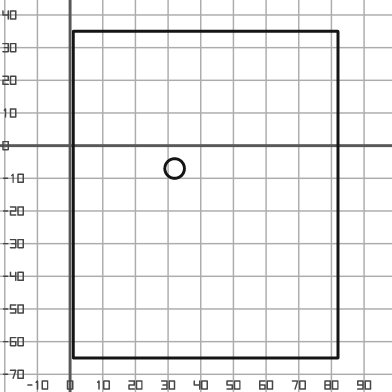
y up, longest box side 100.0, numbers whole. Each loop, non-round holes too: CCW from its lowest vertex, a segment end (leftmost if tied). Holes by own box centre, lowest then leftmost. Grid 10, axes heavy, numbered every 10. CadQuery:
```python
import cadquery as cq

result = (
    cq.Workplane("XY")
    .moveTo(1.0, -65.0)
    .lineTo(82.0, -65.0)
    .lineTo(82.0, 35.0)
    .lineTo(1.0, 35.0)
    .close()
    .moveTo(32.0, -7.0)
    .circle(3.0)
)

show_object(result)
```